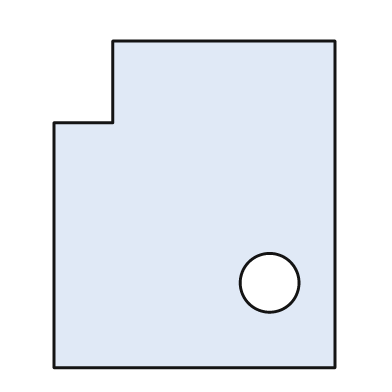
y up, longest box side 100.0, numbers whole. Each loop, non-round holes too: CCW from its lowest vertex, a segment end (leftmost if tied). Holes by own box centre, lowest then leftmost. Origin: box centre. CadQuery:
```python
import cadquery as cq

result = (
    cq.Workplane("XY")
    .moveTo(-43.0, -50.0)
    .lineTo(43.0, -50.0)
    .lineTo(43.0, 50.0)
    .lineTo(-25.0, 50.0)
    .lineTo(-25.0, 25.0)
    .lineTo(-43.0, 25.0)
    .close()
    .moveTo(23.0, -24.0)
    .circle(9.0)
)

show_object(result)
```